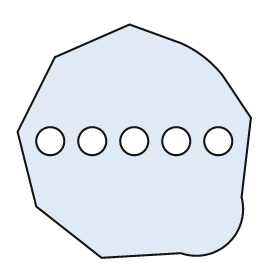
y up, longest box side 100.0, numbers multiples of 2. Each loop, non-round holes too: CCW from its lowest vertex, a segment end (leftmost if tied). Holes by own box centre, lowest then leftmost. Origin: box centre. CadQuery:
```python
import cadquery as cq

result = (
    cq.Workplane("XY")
    .moveTo(-14.0, -50.0)
    .lineTo(20.0, -48.0)
    .threePointArc((40.0, -44.0), (46.0, -24.0))
    .lineTo(50.0, 10.0)
    .lineTo(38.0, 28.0)
    .threePointArc((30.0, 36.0), (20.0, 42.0))
    .lineTo(-2.0, 50.0)
    .lineTo(-34.0, 36.0)
    .lineTo(-50.0, 4.0)
    .lineTo(-42.0, -28.0)
    .close()
    .moveTo(-36.0, 0.0)
    .circle(6.0)
    .moveTo(-18.0, 0.0)
    .circle(6.0)
    .moveTo(0.0, 0.0)
    .circle(6.0)
    .moveTo(18.0, 0.0)
    .circle(6.0)
    .moveTo(36.0, 0.0)
    .circle(6.0)
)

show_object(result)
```